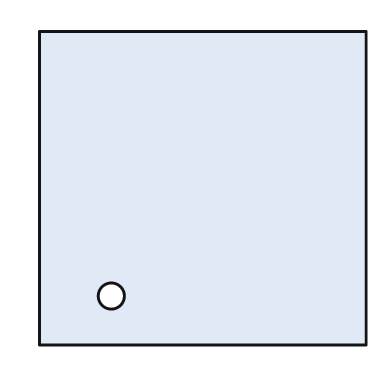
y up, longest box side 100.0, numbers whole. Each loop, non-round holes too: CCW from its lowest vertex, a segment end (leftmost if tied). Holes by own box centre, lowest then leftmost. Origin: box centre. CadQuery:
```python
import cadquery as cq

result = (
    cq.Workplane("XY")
    .moveTo(-50.0, -48.0)
    .lineTo(50.0, -48.0)
    .lineTo(50.0, 48.0)
    .lineTo(-50.0, 48.0)
    .close()
    .moveTo(-28.0, -33.0)
    .circle(4.0)
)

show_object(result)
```